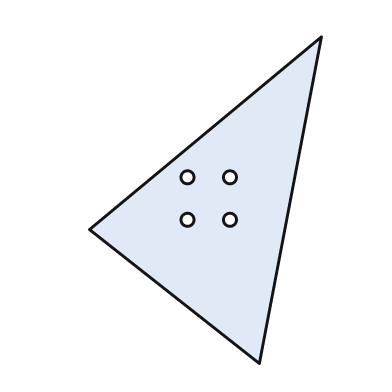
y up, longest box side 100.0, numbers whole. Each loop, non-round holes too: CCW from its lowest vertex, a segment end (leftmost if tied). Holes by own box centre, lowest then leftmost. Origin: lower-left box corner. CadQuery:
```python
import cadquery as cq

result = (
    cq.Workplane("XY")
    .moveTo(52.0, 0.0)
    .lineTo(71.0, 100.0)
    .lineTo(0.0, 41.0)
    .close()
    .moveTo(30.0, 44.0)
    .circle(2.0)
    .moveTo(43.0, 44.0)
    .circle(2.0)
    .moveTo(30.0, 57.0)
    .circle(2.0)
    .moveTo(43.0, 57.0)
    .circle(2.0)
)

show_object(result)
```